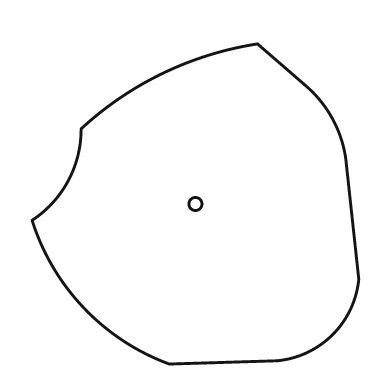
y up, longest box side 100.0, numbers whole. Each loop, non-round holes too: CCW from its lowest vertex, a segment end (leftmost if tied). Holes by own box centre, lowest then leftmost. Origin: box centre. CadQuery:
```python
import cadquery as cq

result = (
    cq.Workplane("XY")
    .moveTo(-8.0, -49.0)
    .lineTo(25.0, -48.0)
    .threePointArc((42.0, -40.0), (50.0, -23.0))
    .lineTo(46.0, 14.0)
    .threePointArc((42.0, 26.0), (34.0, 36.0))
    .lineTo(19.0, 49.0)
    .threePointArc((-10.0, 40.0), (-35.0, 23.0))
    .threePointArc((-39.0, 7.0), (-50.0, -5.0))
    .threePointArc((-34.0, -32.0), (-8.0, -49.0))
    .close()
    .moveTo(0.0, 0.0)
    .circle(2.0)
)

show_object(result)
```